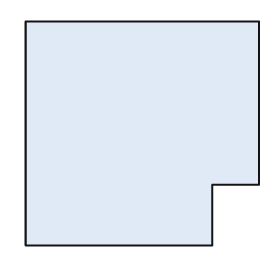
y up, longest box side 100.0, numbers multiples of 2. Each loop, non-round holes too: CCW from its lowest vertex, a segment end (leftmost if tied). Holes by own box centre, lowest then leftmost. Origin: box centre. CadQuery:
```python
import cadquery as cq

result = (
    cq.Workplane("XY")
    .moveTo(-50.0, -48.0)
    .lineTo(30.0, -48.0)
    .lineTo(30.0, -22.0)
    .lineTo(50.0, -22.0)
    .lineTo(50.0, 48.0)
    .lineTo(-50.0, 48.0)
    .close()
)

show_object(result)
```